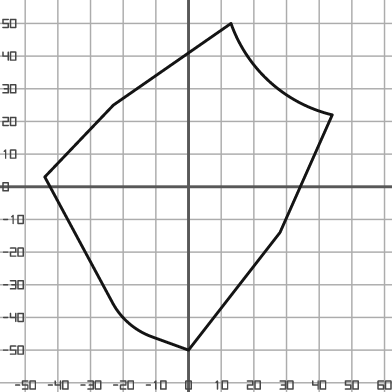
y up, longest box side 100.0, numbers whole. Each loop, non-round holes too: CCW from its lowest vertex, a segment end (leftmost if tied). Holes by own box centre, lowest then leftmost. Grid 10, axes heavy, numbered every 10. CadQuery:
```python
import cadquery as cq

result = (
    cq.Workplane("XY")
    .moveTo(0.0, -50.0)
    .lineTo(28.0, -14.0)
    .lineTo(44.0, 22.0)
    .threePointArc((25.0, 32.0), (13.0, 50.0))
    .lineTo(-23.0, 25.0)
    .lineTo(-44.0, 3.0)
    .lineTo(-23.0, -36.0)
    .threePointArc((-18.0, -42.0), (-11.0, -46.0))
    .close()
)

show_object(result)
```